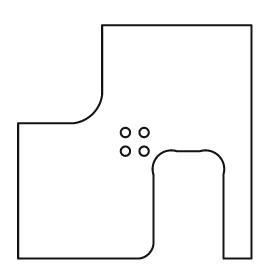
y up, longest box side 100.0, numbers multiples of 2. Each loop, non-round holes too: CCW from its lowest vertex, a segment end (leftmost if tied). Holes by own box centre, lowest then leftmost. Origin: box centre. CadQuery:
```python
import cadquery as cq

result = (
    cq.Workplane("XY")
    .moveTo(-50.0, -50.0)
    .lineTo(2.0, -50.0)
    .threePointArc((6.0, -48.0), (8.0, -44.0))
    .lineTo(8.0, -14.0)
    .threePointArc((10.0, -6.0), (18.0, -4.0))
    .lineTo(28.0, -4.0)
    .threePointArc((36.0, -6.0), (38.0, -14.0))
    .lineTo(38.0, -50.0)
    .lineTo(50.0, -50.0)
    .lineTo(50.0, 50.0)
    .lineTo(-14.0, 50.0)
    .lineTo(-14.0, 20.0)
    .threePointArc((-18.0, 12.0), (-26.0, 8.0))
    .lineTo(-50.0, 8.0)
    .close()
    .moveTo(-4.0, -4.0)
    .circle(2.0)
    .moveTo(4.0, -4.0)
    .circle(2.0)
    .moveTo(-4.0, 4.0)
    .circle(2.0)
    .moveTo(4.0, 4.0)
    .circle(2.0)
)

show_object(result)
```